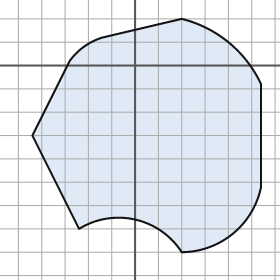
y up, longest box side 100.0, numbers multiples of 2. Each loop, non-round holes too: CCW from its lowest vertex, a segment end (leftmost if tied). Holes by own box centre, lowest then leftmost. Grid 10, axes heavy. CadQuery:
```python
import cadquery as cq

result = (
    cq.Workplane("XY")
    .moveTo(20.0, -80.0)
    .threePointArc((42.0, -72.0), (54.0, -52.0))
    .lineTo(54.0, -8.0)
    .threePointArc((40.0, 10.0), (20.0, 20.0))
    .lineTo(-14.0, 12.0)
    .threePointArc((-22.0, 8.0), (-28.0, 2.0))
    .lineTo(-44.0, -30.0)
    .lineTo(-24.0, -70.0)
    .threePointArc((0.0, -66.0), (20.0, -80.0))
    .close()
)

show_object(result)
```